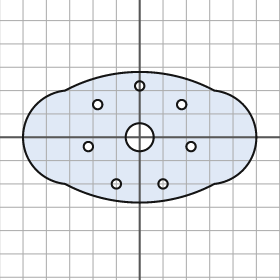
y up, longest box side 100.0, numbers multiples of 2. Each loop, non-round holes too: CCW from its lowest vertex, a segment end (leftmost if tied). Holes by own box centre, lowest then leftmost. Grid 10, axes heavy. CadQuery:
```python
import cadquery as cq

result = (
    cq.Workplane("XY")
    .moveTo(-32.0, -20.0)
    .threePointArc((0.0, -28.0), (32.0, -20.0))
    .threePointArc((50.0, 0.0), (32.0, 20.0))
    .threePointArc((0.0, 28.0), (-32.0, 20.0))
    .threePointArc((-50.0, 0.0), (-32.0, -20.0))
    .close()
    .moveTo(-10.0, -20.0)
    .circle(2.0)
    .moveTo(10.0, -20.0)
    .circle(2.0)
    .moveTo(-22.0, -4.0)
    .circle(2.0)
    .moveTo(22.0, -4.0)
    .circle(2.0)
    .moveTo(0.0, 0.0)
    .circle(6.0)
    .moveTo(-18.0, 14.0)
    .circle(2.0)
    .moveTo(18.0, 14.0)
    .circle(2.0)
    .moveTo(0.0, 22.0)
    .circle(2.0)
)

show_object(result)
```